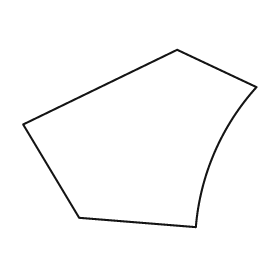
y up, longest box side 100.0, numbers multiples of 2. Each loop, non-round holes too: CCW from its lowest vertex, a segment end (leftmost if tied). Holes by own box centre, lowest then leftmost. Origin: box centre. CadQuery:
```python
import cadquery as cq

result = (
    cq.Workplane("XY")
    .moveTo(24.0, -38.0)
    .threePointArc((32.0, -6.0), (50.0, 22.0))
    .lineTo(16.0, 38.0)
    .lineTo(-50.0, 6.0)
    .lineTo(-26.0, -34.0)
    .close()
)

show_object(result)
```